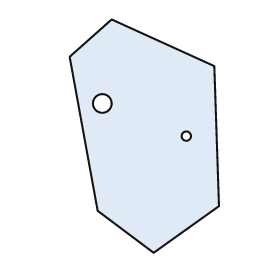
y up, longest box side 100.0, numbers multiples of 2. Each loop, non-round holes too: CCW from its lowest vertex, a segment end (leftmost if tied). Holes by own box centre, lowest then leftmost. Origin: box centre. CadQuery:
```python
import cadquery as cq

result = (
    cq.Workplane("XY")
    .moveTo(4.0, -50.0)
    .lineTo(32.0, -30.0)
    .lineTo(30.0, 30.0)
    .lineTo(-14.0, 50.0)
    .lineTo(-32.0, 34.0)
    .lineTo(-20.0, -32.0)
    .close()
    .moveTo(18.0, 0.0)
    .circle(2.0)
    .moveTo(-18.0, 14.0)
    .circle(4.0)
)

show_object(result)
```